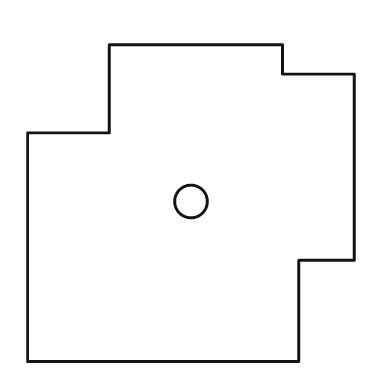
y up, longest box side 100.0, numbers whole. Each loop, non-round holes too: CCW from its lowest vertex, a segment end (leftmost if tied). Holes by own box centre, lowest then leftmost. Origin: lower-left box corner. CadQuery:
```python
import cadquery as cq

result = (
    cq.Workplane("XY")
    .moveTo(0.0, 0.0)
    .lineTo(83.0, 0.0)
    .lineTo(83.0, 31.0)
    .lineTo(100.0, 31.0)
    .lineTo(100.0, 88.0)
    .lineTo(78.0, 88.0)
    .lineTo(78.0, 97.0)
    .lineTo(25.0, 97.0)
    .lineTo(25.0, 70.0)
    .lineTo(0.0, 70.0)
    .close()
    .moveTo(50.0, 49.0)
    .circle(5.0)
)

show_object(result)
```